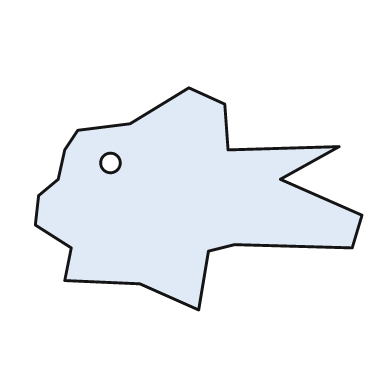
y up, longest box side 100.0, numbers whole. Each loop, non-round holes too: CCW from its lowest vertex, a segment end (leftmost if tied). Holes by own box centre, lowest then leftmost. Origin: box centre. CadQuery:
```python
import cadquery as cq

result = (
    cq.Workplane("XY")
    .moveTo(0.0, -34.0)
    .lineTo(3.0, -16.0)
    .lineTo(11.0, -14.0)
    .lineTo(47.0, -15.0)
    .lineTo(50.0, -5.0)
    .lineTo(25.0, 6.0)
    .lineTo(43.0, 16.0)
    .lineTo(9.0, 15.0)
    .lineTo(8.0, 29.0)
    .lineTo(-3.0, 34.0)
    .lineTo(-21.0, 23.0)
    .lineTo(-37.0, 21.0)
    .lineTo(-41.0, 15.0)
    .lineTo(-43.0, 6.0)
    .lineTo(-49.0, 1.0)
    .lineTo(-50.0, -8.0)
    .lineTo(-39.0, -15.0)
    .lineTo(-41.0, -25.0)
    .lineTo(-18.0, -26.0)
    .close()
    .moveTo(-27.0, 11.0)
    .circle(3.0)
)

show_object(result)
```